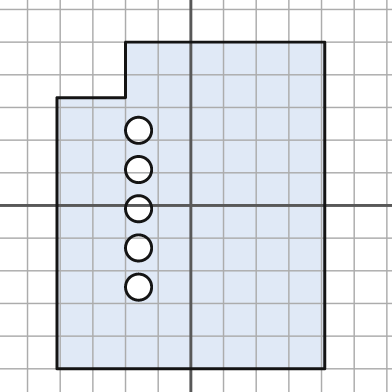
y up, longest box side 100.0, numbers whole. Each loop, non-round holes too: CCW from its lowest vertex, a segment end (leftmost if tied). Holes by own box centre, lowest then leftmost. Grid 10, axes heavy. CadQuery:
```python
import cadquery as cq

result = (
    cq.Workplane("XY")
    .moveTo(-41.0, -50.0)
    .lineTo(41.0, -50.0)
    .lineTo(41.0, 50.0)
    .lineTo(-20.0, 50.0)
    .lineTo(-20.0, 33.0)
    .lineTo(-41.0, 33.0)
    .close()
    .moveTo(-16.0, -25.0)
    .circle(4.0)
    .moveTo(-16.0, -13.0)
    .circle(4.0)
    .moveTo(-16.0, -1.0)
    .circle(4.0)
    .moveTo(-16.0, 11.0)
    .circle(4.0)
    .moveTo(-16.0, 23.0)
    .circle(4.0)
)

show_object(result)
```